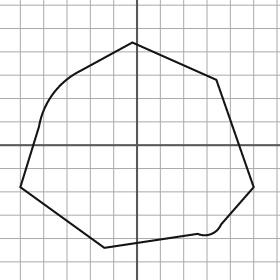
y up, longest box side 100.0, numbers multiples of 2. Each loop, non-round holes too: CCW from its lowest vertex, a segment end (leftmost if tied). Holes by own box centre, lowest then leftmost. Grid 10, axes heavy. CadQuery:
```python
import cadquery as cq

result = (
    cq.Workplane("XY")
    .moveTo(-14.0, -44.0)
    .lineTo(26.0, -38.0)
    .threePointArc((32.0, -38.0), (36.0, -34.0))
    .lineTo(50.0, -18.0)
    .lineTo(34.0, 28.0)
    .lineTo(-2.0, 44.0)
    .lineTo(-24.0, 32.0)
    .threePointArc((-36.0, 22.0), (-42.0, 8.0))
    .lineTo(-50.0, -18.0)
    .close()
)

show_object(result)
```